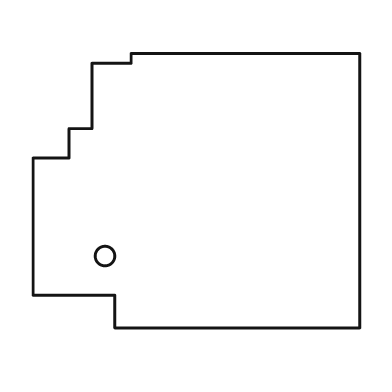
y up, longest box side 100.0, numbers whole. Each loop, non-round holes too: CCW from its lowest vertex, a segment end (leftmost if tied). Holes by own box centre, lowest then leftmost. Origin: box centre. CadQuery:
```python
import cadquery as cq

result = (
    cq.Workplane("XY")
    .moveTo(-25.0, -42.0)
    .lineTo(50.0, -42.0)
    .lineTo(50.0, 42.0)
    .lineTo(-20.0, 42.0)
    .lineTo(-20.0, 39.0)
    .lineTo(-32.0, 39.0)
    .lineTo(-32.0, 19.0)
    .lineTo(-39.0, 19.0)
    .lineTo(-39.0, 10.0)
    .lineTo(-50.0, 10.0)
    .lineTo(-50.0, -32.0)
    .lineTo(-25.0, -32.0)
    .close()
    .moveTo(-28.0, -20.0)
    .circle(3.0)
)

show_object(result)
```